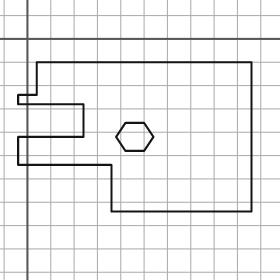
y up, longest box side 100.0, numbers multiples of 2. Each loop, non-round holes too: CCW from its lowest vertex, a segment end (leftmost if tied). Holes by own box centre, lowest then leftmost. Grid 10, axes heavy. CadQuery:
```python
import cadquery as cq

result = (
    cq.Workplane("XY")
    .moveTo(36.0, -74.0)
    .lineTo(96.0, -74.0)
    .lineTo(96.0, -10.0)
    .lineTo(4.0, -10.0)
    .lineTo(4.0, -24.0)
    .lineTo(-4.0, -24.0)
    .lineTo(-4.0, -28.0)
    .lineTo(24.0, -28.0)
    .lineTo(24.0, -42.0)
    .lineTo(-4.0, -42.0)
    .lineTo(-4.0, -54.0)
    .lineTo(36.0, -54.0)
    .close()
    .moveTo(42.0, -48.0)
    .lineTo(50.0, -48.0)
    .lineTo(54.0, -42.0)
    .lineTo(50.0, -36.0)
    .lineTo(42.0, -36.0)
    .lineTo(38.0, -42.0)
    .close()
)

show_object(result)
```